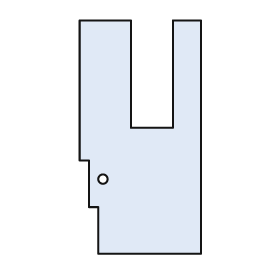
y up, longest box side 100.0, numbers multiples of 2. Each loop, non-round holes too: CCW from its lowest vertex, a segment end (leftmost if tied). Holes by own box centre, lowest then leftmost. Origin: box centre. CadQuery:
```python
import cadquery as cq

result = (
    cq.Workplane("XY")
    .moveTo(-18.0, -50.0)
    .lineTo(26.0, -50.0)
    .lineTo(26.0, 50.0)
    .lineTo(14.0, 50.0)
    .lineTo(14.0, 4.0)
    .lineTo(-4.0, 4.0)
    .lineTo(-4.0, 50.0)
    .lineTo(-26.0, 50.0)
    .lineTo(-26.0, -10.0)
    .lineTo(-22.0, -10.0)
    .lineTo(-22.0, -30.0)
    .lineTo(-18.0, -30.0)
    .close()
    .moveTo(-16.0, -18.0)
    .circle(2.0)
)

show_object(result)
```